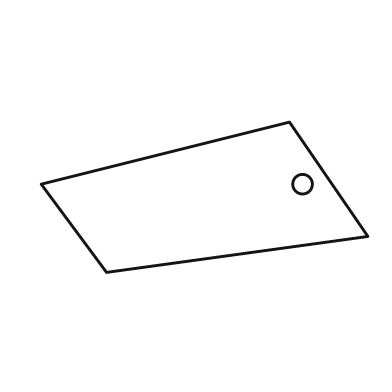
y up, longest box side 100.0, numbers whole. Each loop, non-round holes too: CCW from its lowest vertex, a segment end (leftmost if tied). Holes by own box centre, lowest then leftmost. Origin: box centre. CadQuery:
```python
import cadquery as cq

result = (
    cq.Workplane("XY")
    .moveTo(-30.0, -23.0)
    .lineTo(50.0, -12.0)
    .lineTo(26.0, 23.0)
    .lineTo(-50.0, 4.0)
    .close()
    .moveTo(30.0, 4.0)
    .circle(3.0)
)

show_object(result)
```